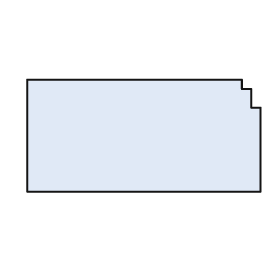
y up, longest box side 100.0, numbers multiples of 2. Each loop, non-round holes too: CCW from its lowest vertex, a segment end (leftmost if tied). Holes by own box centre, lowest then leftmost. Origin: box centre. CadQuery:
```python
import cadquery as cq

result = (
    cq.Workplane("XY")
    .moveTo(-50.0, -24.0)
    .lineTo(50.0, -24.0)
    .lineTo(50.0, 12.0)
    .lineTo(46.0, 12.0)
    .lineTo(46.0, 20.0)
    .lineTo(42.0, 20.0)
    .lineTo(42.0, 24.0)
    .lineTo(-50.0, 24.0)
    .close()
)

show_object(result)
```